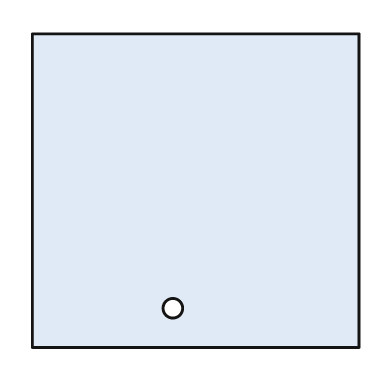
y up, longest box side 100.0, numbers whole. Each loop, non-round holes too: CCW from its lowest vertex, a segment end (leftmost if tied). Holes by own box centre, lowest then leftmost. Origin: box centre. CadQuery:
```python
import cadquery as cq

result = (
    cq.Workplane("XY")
    .moveTo(-50.0, -48.0)
    .lineTo(50.0, -48.0)
    .lineTo(50.0, 48.0)
    .lineTo(-50.0, 48.0)
    .close()
    .moveTo(-7.0, -36.0)
    .circle(3.0)
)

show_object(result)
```